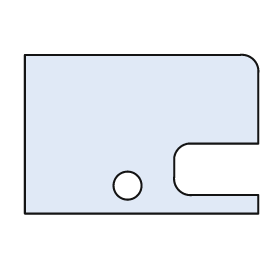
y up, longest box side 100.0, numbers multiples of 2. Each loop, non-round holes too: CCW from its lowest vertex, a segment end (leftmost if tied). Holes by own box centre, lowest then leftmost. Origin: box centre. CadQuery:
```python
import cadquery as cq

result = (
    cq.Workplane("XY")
    .moveTo(-50.0, -34.0)
    .lineTo(50.0, -34.0)
    .lineTo(50.0, -26.0)
    .lineTo(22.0, -26.0)
    .threePointArc((16.0, -24.0), (14.0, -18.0))
    .lineTo(14.0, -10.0)
    .threePointArc((16.0, -6.0), (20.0, -4.0))
    .lineTo(50.0, -4.0)
    .lineTo(50.0, 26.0)
    .threePointArc((48.0, 32.0), (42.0, 34.0))
    .lineTo(-50.0, 34.0)
    .close()
    .moveTo(-6.0, -22.0)
    .circle(6.0)
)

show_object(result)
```